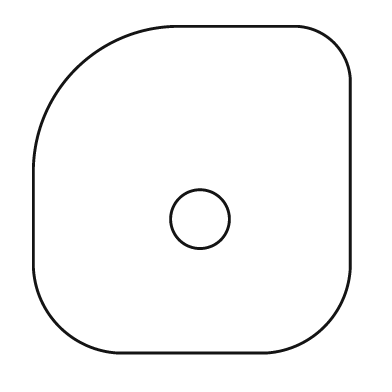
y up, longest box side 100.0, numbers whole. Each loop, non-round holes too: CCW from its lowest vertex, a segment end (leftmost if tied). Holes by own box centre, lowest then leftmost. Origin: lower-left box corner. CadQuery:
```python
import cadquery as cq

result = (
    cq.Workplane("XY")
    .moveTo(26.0, 0.0)
    .lineTo(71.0, 0.0)
    .threePointArc((89.0, 8.0), (97.0, 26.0))
    .lineTo(97.0, 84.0)
    .threePointArc((92.0, 95.0), (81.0, 100.0))
    .lineTo(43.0, 100.0)
    .threePointArc((13.0, 87.0), (0.0, 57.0))
    .lineTo(0.0, 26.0)
    .threePointArc((8.0, 8.0), (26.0, 0.0))
    .close()
    .moveTo(51.0, 41.0)
    .circle(9.0)
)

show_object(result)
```